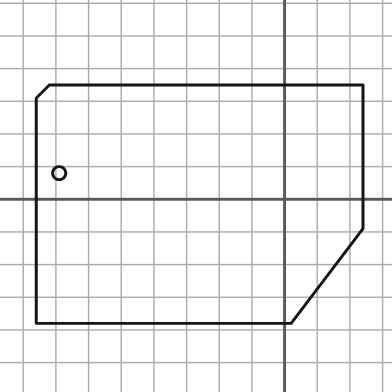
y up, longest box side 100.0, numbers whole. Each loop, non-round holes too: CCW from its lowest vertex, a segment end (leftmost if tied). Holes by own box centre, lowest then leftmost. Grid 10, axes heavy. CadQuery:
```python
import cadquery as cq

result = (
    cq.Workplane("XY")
    .moveTo(-76.0, -38.0)
    .lineTo(2.0, -38.0)
    .lineTo(24.0, -9.0)
    .lineTo(24.0, 35.0)
    .lineTo(-72.0, 35.0)
    .lineTo(-76.0, 31.0)
    .close()
    .moveTo(-69.0, 8.0)
    .circle(2.0)
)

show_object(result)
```